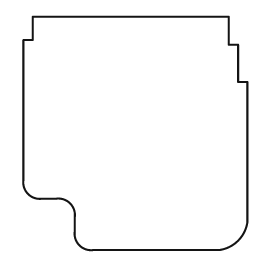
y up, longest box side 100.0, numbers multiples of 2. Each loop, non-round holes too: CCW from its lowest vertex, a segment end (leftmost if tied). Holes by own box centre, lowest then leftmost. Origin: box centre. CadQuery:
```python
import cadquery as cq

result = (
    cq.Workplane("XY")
    .moveTo(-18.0, -50.0)
    .lineTo(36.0, -50.0)
    .threePointArc((44.0, -46.0), (48.0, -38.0))
    .lineTo(48.0, 22.0)
    .lineTo(44.0, 22.0)
    .lineTo(44.0, 38.0)
    .lineTo(40.0, 38.0)
    .lineTo(40.0, 50.0)
    .lineTo(-44.0, 50.0)
    .lineTo(-44.0, 40.0)
    .lineTo(-48.0, 40.0)
    .lineTo(-48.0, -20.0)
    .threePointArc((-46.0, -26.0), (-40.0, -28.0))
    .lineTo(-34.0, -28.0)
    .threePointArc((-28.0, -30.0), (-26.0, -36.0))
    .lineTo(-26.0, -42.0)
    .threePointArc((-24.0, -48.0), (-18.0, -50.0))
    .close()
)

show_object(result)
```